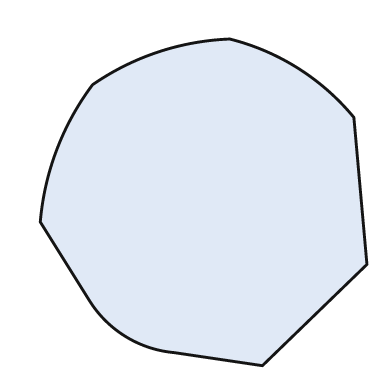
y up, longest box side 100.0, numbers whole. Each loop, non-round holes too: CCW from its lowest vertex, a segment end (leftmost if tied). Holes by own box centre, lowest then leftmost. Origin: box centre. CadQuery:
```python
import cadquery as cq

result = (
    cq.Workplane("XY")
    .moveTo(18.0, -50.0)
    .lineTo(50.0, -19.0)
    .lineTo(46.0, 26.0)
    .threePointArc((29.0, 41.0), (8.0, 50.0))
    .threePointArc((-14.0, 46.0), (-34.0, 36.0))
    .threePointArc((-45.0, 16.0), (-50.0, -6.0))
    .lineTo(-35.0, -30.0)
    .threePointArc((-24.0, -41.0), (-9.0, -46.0))
    .close()
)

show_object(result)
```